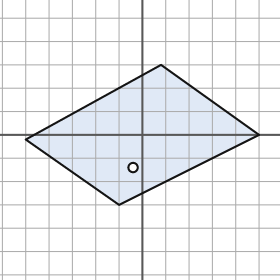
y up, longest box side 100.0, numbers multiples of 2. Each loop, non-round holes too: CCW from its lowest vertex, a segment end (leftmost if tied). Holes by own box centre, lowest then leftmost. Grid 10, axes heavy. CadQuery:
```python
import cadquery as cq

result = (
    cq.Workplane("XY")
    .moveTo(-10.0, -30.0)
    .lineTo(50.0, 0.0)
    .lineTo(8.0, 30.0)
    .lineTo(-50.0, -2.0)
    .close()
    .moveTo(-4.0, -14.0)
    .circle(2.0)
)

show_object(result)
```